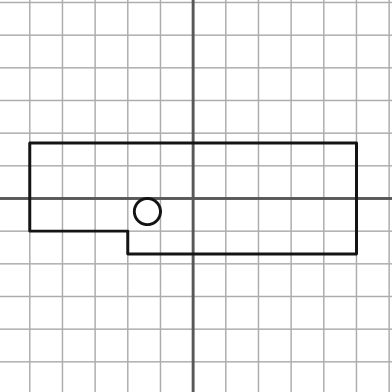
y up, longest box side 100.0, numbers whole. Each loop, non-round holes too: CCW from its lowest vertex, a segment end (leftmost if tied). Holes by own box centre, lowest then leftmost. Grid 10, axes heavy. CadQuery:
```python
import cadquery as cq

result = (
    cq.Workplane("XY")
    .moveTo(-20.0, -17.0)
    .lineTo(50.0, -17.0)
    .lineTo(50.0, 17.0)
    .lineTo(-50.0, 17.0)
    .lineTo(-50.0, -10.0)
    .lineTo(-20.0, -10.0)
    .close()
    .moveTo(-14.0, -4.0)
    .circle(4.0)
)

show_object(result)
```